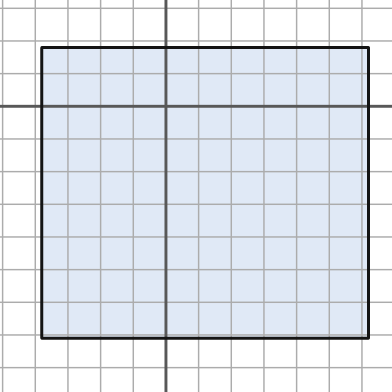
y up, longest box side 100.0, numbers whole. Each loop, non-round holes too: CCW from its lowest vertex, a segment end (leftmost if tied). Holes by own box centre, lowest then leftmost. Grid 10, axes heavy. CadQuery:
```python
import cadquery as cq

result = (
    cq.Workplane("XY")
    .moveTo(-38.0, -71.0)
    .lineTo(62.0, -71.0)
    .lineTo(62.0, 18.0)
    .lineTo(-38.0, 18.0)
    .close()
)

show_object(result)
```